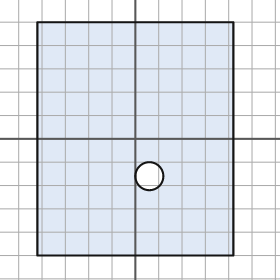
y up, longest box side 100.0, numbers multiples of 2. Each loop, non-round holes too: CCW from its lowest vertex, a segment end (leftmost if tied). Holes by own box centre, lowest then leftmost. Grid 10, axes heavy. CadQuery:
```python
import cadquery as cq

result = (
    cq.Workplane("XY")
    .moveTo(-42.0, -50.0)
    .lineTo(42.0, -50.0)
    .lineTo(42.0, 50.0)
    .lineTo(-42.0, 50.0)
    .close()
    .moveTo(6.0, -16.0)
    .circle(6.0)
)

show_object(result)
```